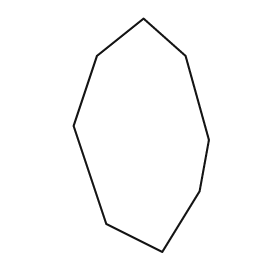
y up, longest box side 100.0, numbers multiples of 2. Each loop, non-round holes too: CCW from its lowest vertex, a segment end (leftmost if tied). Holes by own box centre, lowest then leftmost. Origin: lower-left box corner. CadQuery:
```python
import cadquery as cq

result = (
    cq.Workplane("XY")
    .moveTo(38.0, 0.0)
    .lineTo(54.0, 26.0)
    .lineTo(58.0, 48.0)
    .lineTo(48.0, 84.0)
    .lineTo(30.0, 100.0)
    .lineTo(10.0, 84.0)
    .lineTo(0.0, 54.0)
    .lineTo(14.0, 12.0)
    .close()
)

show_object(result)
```